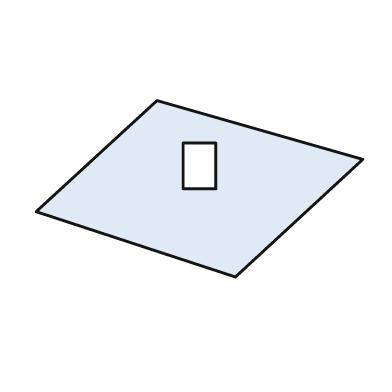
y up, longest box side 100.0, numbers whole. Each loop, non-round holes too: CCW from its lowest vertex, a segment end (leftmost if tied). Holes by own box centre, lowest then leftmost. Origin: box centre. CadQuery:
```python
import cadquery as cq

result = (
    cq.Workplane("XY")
    .moveTo(11.0, -27.0)
    .lineTo(50.0, 9.0)
    .lineTo(-13.0, 27.0)
    .lineTo(-50.0, -7.0)
    .close()
    .moveTo(-5.0, 0.0)
    .lineTo(5.0, 0.0)
    .lineTo(5.0, 14.0)
    .lineTo(-5.0, 14.0)
    .close()
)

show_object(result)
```